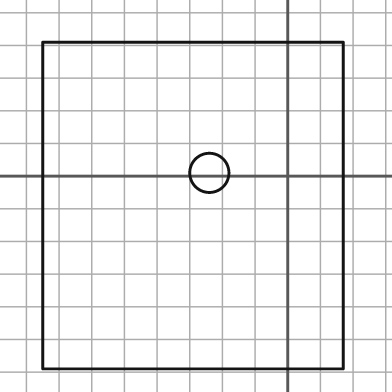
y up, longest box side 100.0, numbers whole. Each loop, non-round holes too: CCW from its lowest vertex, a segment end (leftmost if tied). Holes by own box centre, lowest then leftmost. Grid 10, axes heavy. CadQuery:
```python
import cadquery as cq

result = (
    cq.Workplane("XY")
    .moveTo(-75.0, -59.0)
    .lineTo(17.0, -59.0)
    .lineTo(17.0, 41.0)
    .lineTo(-75.0, 41.0)
    .close()
    .moveTo(-24.0, 1.0)
    .circle(6.0)
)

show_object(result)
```